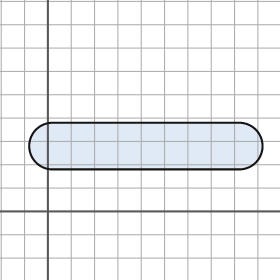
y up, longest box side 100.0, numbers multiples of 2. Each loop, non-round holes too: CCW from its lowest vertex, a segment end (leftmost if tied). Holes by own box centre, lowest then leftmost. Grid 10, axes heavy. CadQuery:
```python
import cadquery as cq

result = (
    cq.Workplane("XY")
    .moveTo(2.0, 18.0)
    .lineTo(82.0, 18.0)
    .threePointArc((92.0, 28.0), (82.0, 38.0))
    .lineTo(2.0, 38.0)
    .threePointArc((-8.0, 28.0), (2.0, 18.0))
    .close()
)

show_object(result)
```